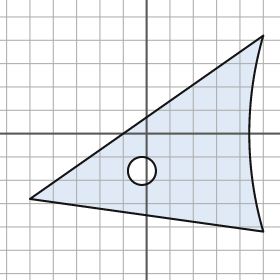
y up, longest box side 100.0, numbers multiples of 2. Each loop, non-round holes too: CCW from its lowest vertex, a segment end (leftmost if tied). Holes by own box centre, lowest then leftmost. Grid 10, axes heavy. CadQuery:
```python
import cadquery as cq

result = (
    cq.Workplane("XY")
    .moveTo(50.0, -42.0)
    .threePointArc((44.0, 0.0), (50.0, 42.0))
    .lineTo(-50.0, -28.0)
    .close()
    .moveTo(-2.0, -16.0)
    .circle(6.0)
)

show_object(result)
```